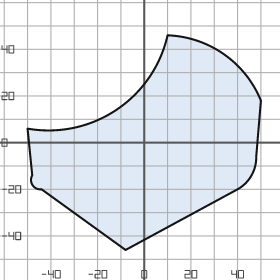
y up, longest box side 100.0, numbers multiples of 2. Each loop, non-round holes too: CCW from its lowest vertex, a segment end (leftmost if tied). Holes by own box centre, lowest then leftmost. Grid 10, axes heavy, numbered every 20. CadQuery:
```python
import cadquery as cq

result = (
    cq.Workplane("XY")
    .moveTo(-8.0, -46.0)
    .lineTo(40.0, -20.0)
    .threePointArc((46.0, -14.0), (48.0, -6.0))
    .lineTo(50.0, 18.0)
    .threePointArc((34.0, 38.0), (10.0, 46.0))
    .threePointArc((-12.0, 14.0), (-50.0, 6.0))
    .lineTo(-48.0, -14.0)
    .threePointArc((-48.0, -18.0), (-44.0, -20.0))
    .close()
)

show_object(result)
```